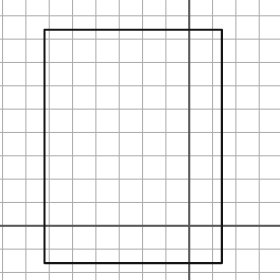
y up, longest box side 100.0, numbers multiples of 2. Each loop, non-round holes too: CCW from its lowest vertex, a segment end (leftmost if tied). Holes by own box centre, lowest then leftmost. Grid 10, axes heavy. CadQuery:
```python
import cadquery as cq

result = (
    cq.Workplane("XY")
    .moveTo(-62.0, -16.0)
    .lineTo(14.0, -16.0)
    .lineTo(14.0, 84.0)
    .lineTo(-62.0, 84.0)
    .close()
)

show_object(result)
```